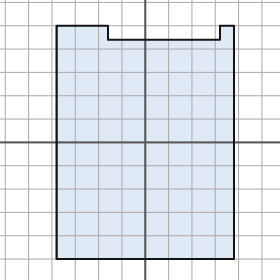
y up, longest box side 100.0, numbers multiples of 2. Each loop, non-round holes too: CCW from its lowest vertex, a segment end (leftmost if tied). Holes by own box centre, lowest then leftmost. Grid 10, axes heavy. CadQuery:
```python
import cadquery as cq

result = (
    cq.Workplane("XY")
    .moveTo(-38.0, -50.0)
    .lineTo(38.0, -50.0)
    .lineTo(38.0, 50.0)
    .lineTo(32.0, 50.0)
    .lineTo(32.0, 44.0)
    .lineTo(-16.0, 44.0)
    .lineTo(-16.0, 50.0)
    .lineTo(-38.0, 50.0)
    .close()
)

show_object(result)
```